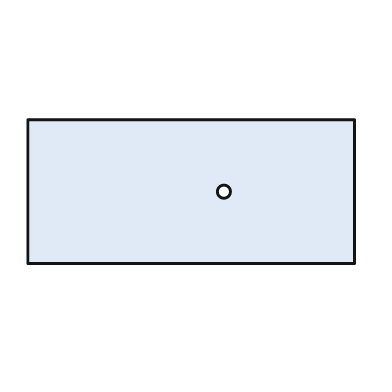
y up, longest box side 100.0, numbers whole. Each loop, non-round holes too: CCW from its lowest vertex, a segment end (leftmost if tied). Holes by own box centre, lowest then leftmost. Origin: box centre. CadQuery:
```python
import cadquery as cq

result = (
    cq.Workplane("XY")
    .moveTo(-50.0, -22.0)
    .lineTo(50.0, -22.0)
    .lineTo(50.0, 22.0)
    .lineTo(-50.0, 22.0)
    .close()
    .moveTo(10.0, 0.0)
    .circle(2.0)
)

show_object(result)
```